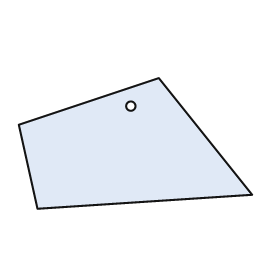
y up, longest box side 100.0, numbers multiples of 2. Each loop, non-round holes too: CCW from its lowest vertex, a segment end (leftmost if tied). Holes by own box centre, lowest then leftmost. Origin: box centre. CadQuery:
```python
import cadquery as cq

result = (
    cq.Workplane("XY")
    .moveTo(-42.0, -28.0)
    .lineTo(50.0, -22.0)
    .lineTo(10.0, 28.0)
    .lineTo(-50.0, 8.0)
    .close()
    .moveTo(-2.0, 16.0)
    .circle(2.0)
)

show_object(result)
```